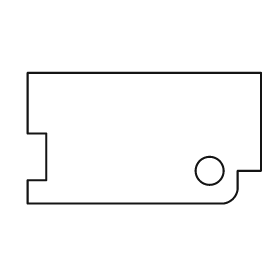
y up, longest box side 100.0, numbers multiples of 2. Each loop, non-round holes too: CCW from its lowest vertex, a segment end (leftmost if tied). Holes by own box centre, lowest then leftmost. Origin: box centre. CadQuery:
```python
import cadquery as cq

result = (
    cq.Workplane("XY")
    .moveTo(-50.0, -28.0)
    .lineTo(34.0, -28.0)
    .threePointArc((38.0, -26.0), (40.0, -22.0))
    .lineTo(40.0, -14.0)
    .lineTo(50.0, -14.0)
    .lineTo(50.0, 28.0)
    .lineTo(-50.0, 28.0)
    .lineTo(-50.0, 2.0)
    .lineTo(-42.0, 2.0)
    .lineTo(-42.0, -18.0)
    .lineTo(-50.0, -18.0)
    .close()
    .moveTo(28.0, -14.0)
    .circle(6.0)
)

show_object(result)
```